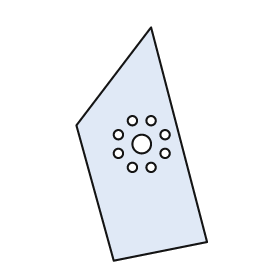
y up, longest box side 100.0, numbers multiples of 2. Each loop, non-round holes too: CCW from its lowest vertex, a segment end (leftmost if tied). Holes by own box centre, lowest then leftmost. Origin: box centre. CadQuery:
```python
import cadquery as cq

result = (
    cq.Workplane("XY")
    .moveTo(-12.0, -50.0)
    .lineTo(28.0, -42.0)
    .lineTo(4.0, 50.0)
    .lineTo(-28.0, 8.0)
    .close()
    .moveTo(-4.0, -10.0)
    .circle(2.0)
    .moveTo(4.0, -10.0)
    .circle(2.0)
    .moveTo(-10.0, -4.0)
    .circle(2.0)
    .moveTo(10.0, -4.0)
    .circle(2.0)
    .moveTo(0.0, 0.0)
    .circle(4.0)
    .moveTo(-10.0, 4.0)
    .circle(2.0)
    .moveTo(10.0, 4.0)
    .circle(2.0)
    .moveTo(-4.0, 10.0)
    .circle(2.0)
    .moveTo(4.0, 10.0)
    .circle(2.0)
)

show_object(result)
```